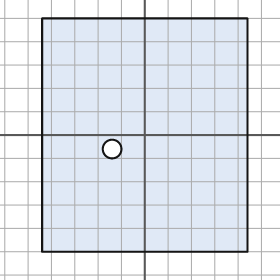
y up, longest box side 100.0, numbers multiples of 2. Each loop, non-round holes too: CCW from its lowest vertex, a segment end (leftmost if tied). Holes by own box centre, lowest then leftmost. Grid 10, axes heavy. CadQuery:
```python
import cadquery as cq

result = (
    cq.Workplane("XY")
    .moveTo(-44.0, -50.0)
    .lineTo(44.0, -50.0)
    .lineTo(44.0, 50.0)
    .lineTo(-44.0, 50.0)
    .close()
    .moveTo(-14.0, -6.0)
    .circle(4.0)
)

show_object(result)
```